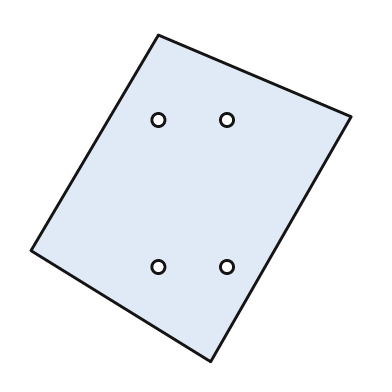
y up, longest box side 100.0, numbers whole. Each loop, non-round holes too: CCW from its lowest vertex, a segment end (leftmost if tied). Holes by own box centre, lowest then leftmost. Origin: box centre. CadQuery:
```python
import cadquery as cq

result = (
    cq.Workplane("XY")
    .moveTo(6.0, -50.0)
    .lineTo(49.0, 25.0)
    .lineTo(-10.0, 50.0)
    .lineTo(-49.0, -16.0)
    .close()
    .moveTo(-10.0, -21.0)
    .circle(2.0)
    .moveTo(11.0, -21.0)
    .circle(2.0)
    .moveTo(-10.0, 24.0)
    .circle(2.0)
    .moveTo(11.0, 24.0)
    .circle(2.0)
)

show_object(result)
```